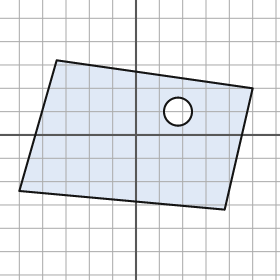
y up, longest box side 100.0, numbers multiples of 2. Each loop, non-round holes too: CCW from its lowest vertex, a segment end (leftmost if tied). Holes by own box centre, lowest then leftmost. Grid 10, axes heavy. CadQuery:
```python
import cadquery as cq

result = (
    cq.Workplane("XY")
    .moveTo(38.0, -32.0)
    .lineTo(50.0, 20.0)
    .lineTo(-34.0, 32.0)
    .lineTo(-50.0, -24.0)
    .close()
    .moveTo(18.0, 10.0)
    .circle(6.0)
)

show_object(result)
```